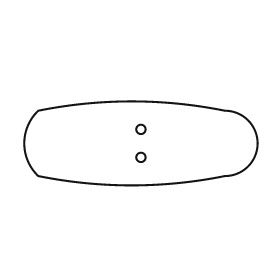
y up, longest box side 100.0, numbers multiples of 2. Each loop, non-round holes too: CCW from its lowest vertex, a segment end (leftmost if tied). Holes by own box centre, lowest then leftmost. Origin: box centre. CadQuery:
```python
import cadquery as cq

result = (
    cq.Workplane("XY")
    .moveTo(-44.0, -14.0)
    .threePointArc((-4.0, -18.0), (36.0, -14.0))
    .threePointArc((50.0, 0.0), (36.0, 14.0))
    .threePointArc((-4.0, 18.0), (-44.0, 14.0))
    .threePointArc((-50.0, 0.0), (-44.0, -14.0))
    .close()
    .moveTo(0.0, -6.0)
    .circle(2.0)
    .moveTo(0.0, 6.0)
    .circle(2.0)
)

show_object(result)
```